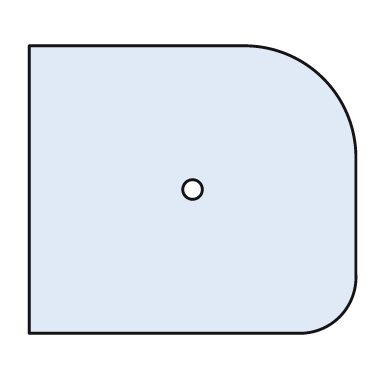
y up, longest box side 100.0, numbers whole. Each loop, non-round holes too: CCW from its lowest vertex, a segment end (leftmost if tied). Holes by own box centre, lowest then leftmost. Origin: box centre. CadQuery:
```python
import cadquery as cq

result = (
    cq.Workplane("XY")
    .moveTo(-50.0, -44.0)
    .lineTo(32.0, -44.0)
    .threePointArc((45.0, -39.0), (50.0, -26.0))
    .lineTo(50.0, 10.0)
    .threePointArc((40.0, 34.0), (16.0, 44.0))
    .lineTo(-50.0, 44.0)
    .close()
    .moveTo(0.0, 0.0)
    .circle(3.0)
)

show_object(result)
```